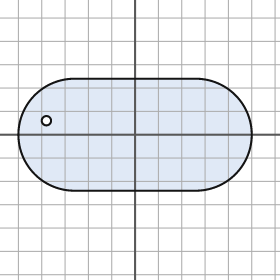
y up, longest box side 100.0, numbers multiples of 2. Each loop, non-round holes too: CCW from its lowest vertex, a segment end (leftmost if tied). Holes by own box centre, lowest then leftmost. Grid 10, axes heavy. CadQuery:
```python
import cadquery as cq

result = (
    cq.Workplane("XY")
    .moveTo(-26.0, -24.0)
    .lineTo(26.0, -24.0)
    .threePointArc((50.0, 0.0), (26.0, 24.0))
    .lineTo(-26.0, 24.0)
    .threePointArc((-50.0, 0.0), (-26.0, -24.0))
    .close()
    .moveTo(-38.0, 6.0)
    .circle(2.0)
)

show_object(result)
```